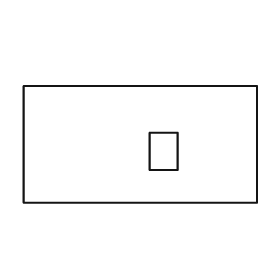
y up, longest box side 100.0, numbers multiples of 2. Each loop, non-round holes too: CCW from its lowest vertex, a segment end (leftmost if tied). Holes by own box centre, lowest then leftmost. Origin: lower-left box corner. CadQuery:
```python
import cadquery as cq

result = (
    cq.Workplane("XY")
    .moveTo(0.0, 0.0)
    .lineTo(100.0, 0.0)
    .lineTo(100.0, 50.0)
    .lineTo(0.0, 50.0)
    .close()
    .moveTo(54.0, 14.0)
    .lineTo(66.0, 14.0)
    .lineTo(66.0, 30.0)
    .lineTo(54.0, 30.0)
    .close()
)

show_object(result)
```